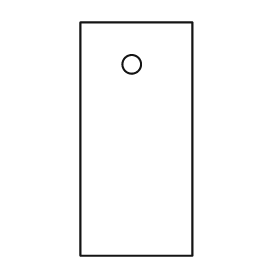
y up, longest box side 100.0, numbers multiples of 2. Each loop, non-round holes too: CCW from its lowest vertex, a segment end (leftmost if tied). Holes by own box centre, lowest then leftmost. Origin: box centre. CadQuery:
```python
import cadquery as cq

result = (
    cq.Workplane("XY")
    .moveTo(-24.0, -50.0)
    .lineTo(24.0, -50.0)
    .lineTo(24.0, 50.0)
    .lineTo(-24.0, 50.0)
    .close()
    .moveTo(-2.0, 32.0)
    .circle(4.0)
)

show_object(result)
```